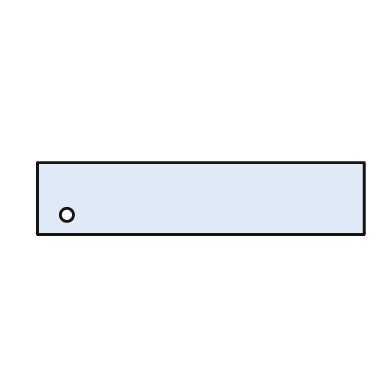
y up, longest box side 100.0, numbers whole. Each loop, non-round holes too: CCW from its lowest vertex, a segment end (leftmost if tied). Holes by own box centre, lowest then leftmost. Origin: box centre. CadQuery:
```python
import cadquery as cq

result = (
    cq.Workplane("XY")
    .moveTo(-50.0, -11.0)
    .lineTo(50.0, -11.0)
    .lineTo(50.0, 11.0)
    .lineTo(-50.0, 11.0)
    .close()
    .moveTo(-41.0, -5.0)
    .circle(2.0)
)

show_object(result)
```